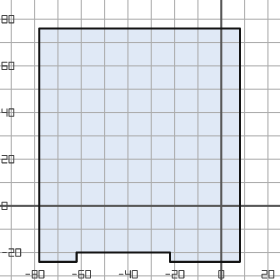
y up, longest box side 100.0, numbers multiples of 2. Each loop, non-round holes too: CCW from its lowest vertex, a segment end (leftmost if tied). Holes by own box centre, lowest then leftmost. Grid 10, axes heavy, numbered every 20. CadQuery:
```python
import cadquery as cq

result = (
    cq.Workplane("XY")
    .moveTo(-78.0, -24.0)
    .lineTo(-62.0, -24.0)
    .lineTo(-62.0, -20.0)
    .lineTo(-22.0, -20.0)
    .lineTo(-22.0, -24.0)
    .lineTo(8.0, -24.0)
    .lineTo(8.0, 76.0)
    .lineTo(-78.0, 76.0)
    .close()
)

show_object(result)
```